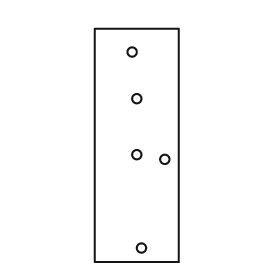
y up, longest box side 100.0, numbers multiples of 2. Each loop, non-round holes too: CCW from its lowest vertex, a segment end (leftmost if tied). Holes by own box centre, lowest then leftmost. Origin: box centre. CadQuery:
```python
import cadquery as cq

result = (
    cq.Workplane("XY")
    .moveTo(-18.0, -50.0)
    .lineTo(18.0, -50.0)
    .lineTo(18.0, 50.0)
    .lineTo(-18.0, 50.0)
    .close()
    .moveTo(2.0, -44.0)
    .circle(2.0)
    .moveTo(12.0, -6.0)
    .circle(2.0)
    .moveTo(0.0, -4.0)
    .circle(2.0)
    .moveTo(0.0, 20.0)
    .circle(2.0)
    .moveTo(-2.0, 40.0)
    .circle(2.0)
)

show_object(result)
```